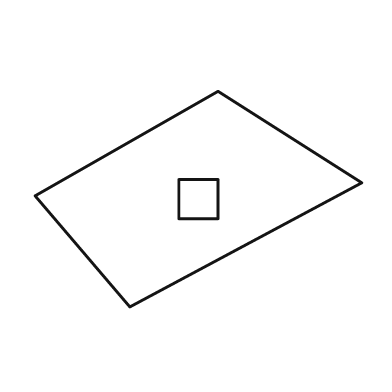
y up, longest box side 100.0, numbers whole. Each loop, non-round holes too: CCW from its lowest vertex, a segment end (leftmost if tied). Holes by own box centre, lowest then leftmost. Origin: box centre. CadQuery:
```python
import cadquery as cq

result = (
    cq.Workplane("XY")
    .moveTo(-21.0, -33.0)
    .lineTo(50.0, 5.0)
    .lineTo(6.0, 33.0)
    .lineTo(-50.0, 1.0)
    .close()
    .moveTo(-6.0, -6.0)
    .lineTo(6.0, -6.0)
    .lineTo(6.0, 6.0)
    .lineTo(-6.0, 6.0)
    .close()
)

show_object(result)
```